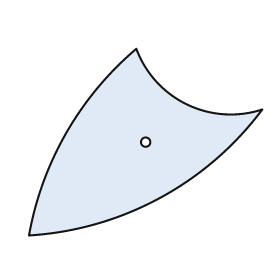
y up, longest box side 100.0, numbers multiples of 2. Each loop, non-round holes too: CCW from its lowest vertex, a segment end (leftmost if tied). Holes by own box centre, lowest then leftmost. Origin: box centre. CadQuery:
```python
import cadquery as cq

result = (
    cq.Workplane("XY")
    .moveTo(-50.0, -40.0)
    .threePointArc((6.0, -24.0), (50.0, 14.0))
    .threePointArc((18.0, 16.0), (-4.0, 40.0))
    .threePointArc((-34.0, 4.0), (-50.0, -40.0))
    .close()
    .moveTo(0.0, 0.0)
    .circle(2.0)
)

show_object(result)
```